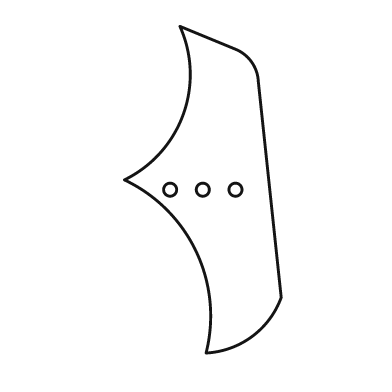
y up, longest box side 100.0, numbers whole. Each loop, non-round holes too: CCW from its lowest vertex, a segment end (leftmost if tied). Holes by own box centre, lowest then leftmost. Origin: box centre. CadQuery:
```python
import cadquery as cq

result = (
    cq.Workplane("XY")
    .moveTo(1.0, -50.0)
    .threePointArc((15.0, -45.0), (24.0, -33.0))
    .lineTo(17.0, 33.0)
    .threePointArc((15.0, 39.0), (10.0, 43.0))
    .lineTo(-7.0, 50.0)
    .threePointArc((-6.0, 23.0), (-24.0, 3.0))
    .threePointArc((-2.0, -19.0), (1.0, -50.0))
    .close()
    .moveTo(-10.0, 0.0)
    .circle(2.0)
    .moveTo(0.0, 0.0)
    .circle(2.0)
    .moveTo(10.0, 0.0)
    .circle(2.0)
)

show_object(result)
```